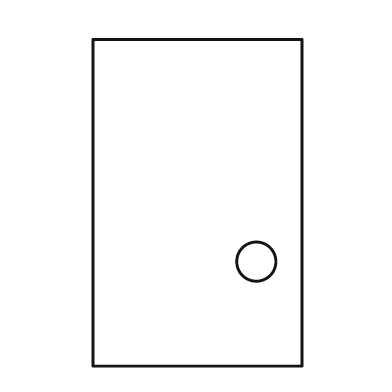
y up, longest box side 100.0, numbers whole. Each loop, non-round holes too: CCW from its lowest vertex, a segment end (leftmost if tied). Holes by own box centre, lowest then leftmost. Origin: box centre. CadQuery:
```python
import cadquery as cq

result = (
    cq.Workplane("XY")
    .moveTo(-32.0, -50.0)
    .lineTo(32.0, -50.0)
    .lineTo(32.0, 50.0)
    .lineTo(-32.0, 50.0)
    .close()
    .moveTo(18.0, -18.0)
    .circle(6.0)
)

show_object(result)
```